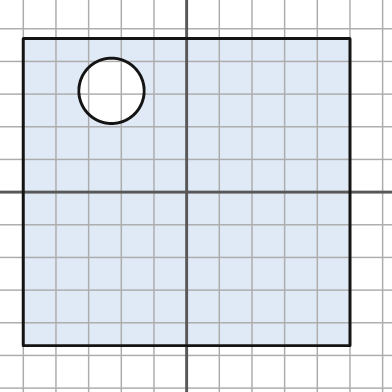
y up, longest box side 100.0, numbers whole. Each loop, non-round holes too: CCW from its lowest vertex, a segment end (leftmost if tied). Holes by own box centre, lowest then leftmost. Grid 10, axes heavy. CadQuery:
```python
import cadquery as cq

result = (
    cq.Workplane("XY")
    .moveTo(-50.0, -47.0)
    .lineTo(50.0, -47.0)
    .lineTo(50.0, 47.0)
    .lineTo(-50.0, 47.0)
    .close()
    .moveTo(-23.0, 31.0)
    .circle(10.0)
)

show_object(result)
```